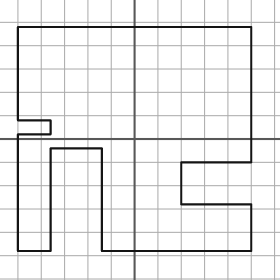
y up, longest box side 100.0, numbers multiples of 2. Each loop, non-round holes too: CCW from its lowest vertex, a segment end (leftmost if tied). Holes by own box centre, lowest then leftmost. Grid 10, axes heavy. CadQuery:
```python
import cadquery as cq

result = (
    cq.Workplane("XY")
    .moveTo(-50.0, -48.0)
    .lineTo(-36.0, -48.0)
    .lineTo(-36.0, -4.0)
    .lineTo(-14.0, -4.0)
    .lineTo(-14.0, -48.0)
    .lineTo(50.0, -48.0)
    .lineTo(50.0, -28.0)
    .lineTo(20.0, -28.0)
    .lineTo(20.0, -10.0)
    .lineTo(50.0, -10.0)
    .lineTo(50.0, 48.0)
    .lineTo(-50.0, 48.0)
    .lineTo(-50.0, 8.0)
    .lineTo(-36.0, 8.0)
    .lineTo(-36.0, 2.0)
    .lineTo(-50.0, 2.0)
    .close()
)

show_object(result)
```